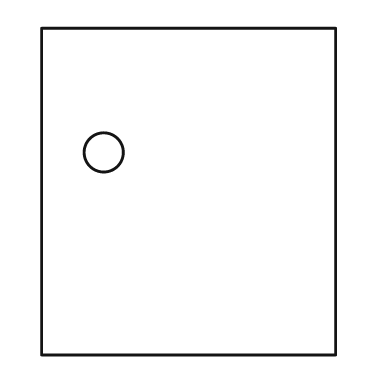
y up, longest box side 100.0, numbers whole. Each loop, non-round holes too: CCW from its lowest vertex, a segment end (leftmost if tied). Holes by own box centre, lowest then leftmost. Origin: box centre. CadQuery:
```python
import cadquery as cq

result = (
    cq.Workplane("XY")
    .moveTo(-45.0, -50.0)
    .lineTo(45.0, -50.0)
    .lineTo(45.0, 50.0)
    .lineTo(-45.0, 50.0)
    .close()
    .moveTo(-26.0, 12.0)
    .circle(6.0)
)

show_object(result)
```